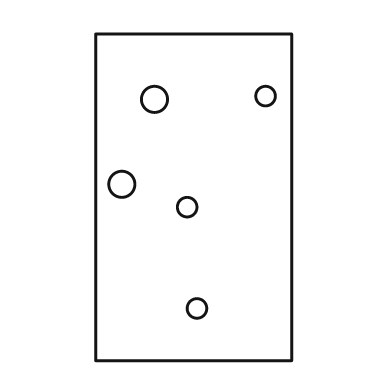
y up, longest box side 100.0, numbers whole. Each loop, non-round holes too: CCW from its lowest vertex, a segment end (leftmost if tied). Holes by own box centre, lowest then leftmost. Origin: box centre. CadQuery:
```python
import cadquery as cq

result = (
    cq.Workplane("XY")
    .moveTo(-30.0, -50.0)
    .lineTo(30.0, -50.0)
    .lineTo(30.0, 50.0)
    .lineTo(-30.0, 50.0)
    .close()
    .moveTo(1.0, -34.0)
    .circle(3.0)
    .moveTo(-2.0, -3.0)
    .circle(3.0)
    .moveTo(-22.0, 4.0)
    .circle(4.0)
    .moveTo(-12.0, 30.0)
    .circle(4.0)
    .moveTo(22.0, 31.0)
    .circle(3.0)
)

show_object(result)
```